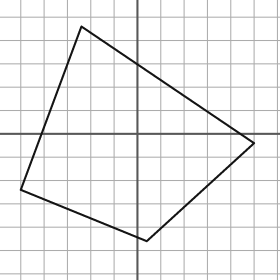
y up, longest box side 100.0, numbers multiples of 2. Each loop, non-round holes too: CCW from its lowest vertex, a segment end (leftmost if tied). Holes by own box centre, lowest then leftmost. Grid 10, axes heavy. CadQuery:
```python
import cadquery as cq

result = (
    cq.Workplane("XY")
    .moveTo(4.0, -46.0)
    .lineTo(50.0, -4.0)
    .lineTo(-24.0, 46.0)
    .lineTo(-50.0, -24.0)
    .close()
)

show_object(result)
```